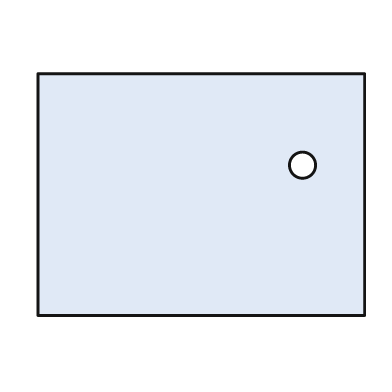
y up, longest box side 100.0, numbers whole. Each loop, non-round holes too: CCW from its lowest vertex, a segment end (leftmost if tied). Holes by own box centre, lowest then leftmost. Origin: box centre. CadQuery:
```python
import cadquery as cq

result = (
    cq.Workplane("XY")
    .moveTo(-50.0, -37.0)
    .lineTo(50.0, -37.0)
    .lineTo(50.0, 37.0)
    .lineTo(-50.0, 37.0)
    .close()
    .moveTo(31.0, 9.0)
    .circle(4.0)
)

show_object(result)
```